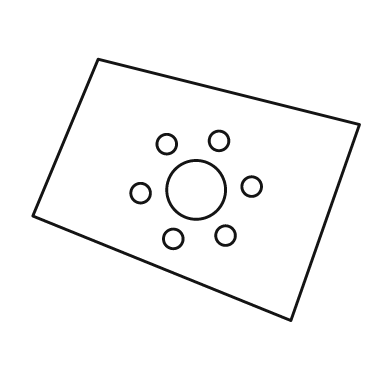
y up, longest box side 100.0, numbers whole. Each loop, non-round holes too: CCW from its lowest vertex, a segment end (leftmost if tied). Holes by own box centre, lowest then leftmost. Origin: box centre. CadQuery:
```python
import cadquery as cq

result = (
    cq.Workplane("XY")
    .moveTo(29.0, -40.0)
    .lineTo(50.0, 20.0)
    .lineTo(-30.0, 40.0)
    .lineTo(-50.0, -8.0)
    .close()
    .moveTo(-7.0, -15.0)
    .circle(3.0)
    .moveTo(9.0, -14.0)
    .circle(3.0)
    .moveTo(-17.0, -1.0)
    .circle(3.0)
    .moveTo(0.0, 0.0)
    .circle(9.0)
    .moveTo(17.0, 1.0)
    .circle(3.0)
    .moveTo(-9.0, 14.0)
    .circle(3.0)
    .moveTo(7.0, 15.0)
    .circle(3.0)
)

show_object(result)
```